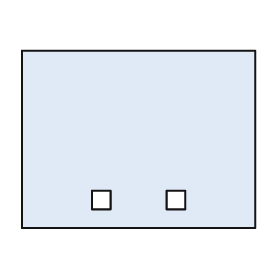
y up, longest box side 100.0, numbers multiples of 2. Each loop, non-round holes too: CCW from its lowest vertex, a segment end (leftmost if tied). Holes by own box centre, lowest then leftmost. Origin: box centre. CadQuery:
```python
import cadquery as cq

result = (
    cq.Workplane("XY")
    .moveTo(-50.0, -38.0)
    .lineTo(50.0, -38.0)
    .lineTo(50.0, 38.0)
    .lineTo(-50.0, 38.0)
    .close()
    .moveTo(-20.0, -30.0)
    .lineTo(-12.0, -30.0)
    .lineTo(-12.0, -22.0)
    .lineTo(-20.0, -22.0)
    .close()
    .moveTo(12.0, -30.0)
    .lineTo(20.0, -30.0)
    .lineTo(20.0, -22.0)
    .lineTo(12.0, -22.0)
    .close()
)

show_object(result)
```